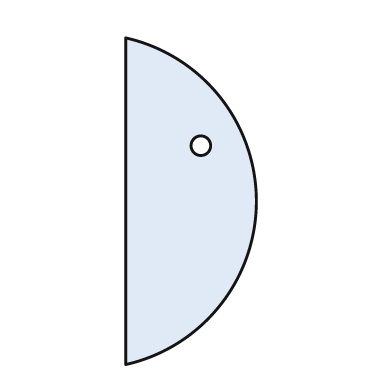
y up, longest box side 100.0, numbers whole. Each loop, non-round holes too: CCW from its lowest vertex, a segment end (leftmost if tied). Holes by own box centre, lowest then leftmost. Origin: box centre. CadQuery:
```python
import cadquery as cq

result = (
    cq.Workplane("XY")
    .moveTo(-20.0, -50.0)
    .threePointArc((20.0, 0.0), (-20.0, 50.0))
    .close()
    .moveTo(3.0, 17.0)
    .circle(3.0)
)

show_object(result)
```